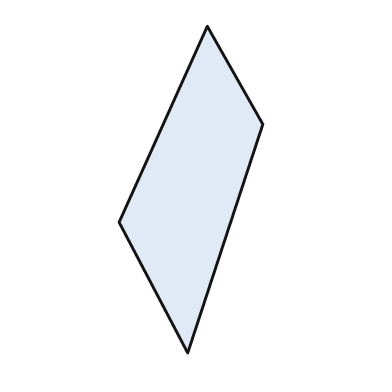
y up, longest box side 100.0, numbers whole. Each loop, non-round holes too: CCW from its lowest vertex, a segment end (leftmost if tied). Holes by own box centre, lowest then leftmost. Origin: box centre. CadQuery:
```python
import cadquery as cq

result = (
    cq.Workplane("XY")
    .moveTo(-1.0, -50.0)
    .lineTo(22.0, 20.0)
    .lineTo(5.0, 50.0)
    .lineTo(-22.0, -10.0)
    .close()
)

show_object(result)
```